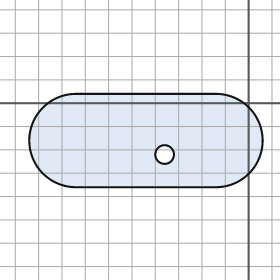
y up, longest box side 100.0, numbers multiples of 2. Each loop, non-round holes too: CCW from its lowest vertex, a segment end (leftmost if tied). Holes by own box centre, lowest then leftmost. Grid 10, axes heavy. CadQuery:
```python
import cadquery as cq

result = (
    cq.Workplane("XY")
    .moveTo(-74.0, -36.0)
    .lineTo(-14.0, -36.0)
    .threePointArc((6.0, -16.0), (-14.0, 4.0))
    .lineTo(-74.0, 4.0)
    .threePointArc((-94.0, -16.0), (-74.0, -36.0))
    .close()
    .moveTo(-36.0, -22.0)
    .circle(4.0)
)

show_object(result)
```